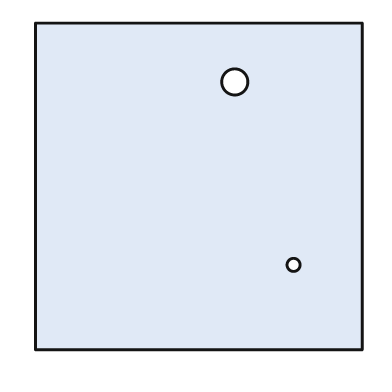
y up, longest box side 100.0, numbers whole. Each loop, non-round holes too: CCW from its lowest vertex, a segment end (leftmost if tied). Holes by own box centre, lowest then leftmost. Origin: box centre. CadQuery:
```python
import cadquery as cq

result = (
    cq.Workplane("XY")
    .moveTo(-50.0, -50.0)
    .lineTo(50.0, -50.0)
    .lineTo(50.0, 50.0)
    .lineTo(-50.0, 50.0)
    .close()
    .moveTo(29.0, -24.0)
    .circle(2.0)
    .moveTo(11.0, 32.0)
    .circle(4.0)
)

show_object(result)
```